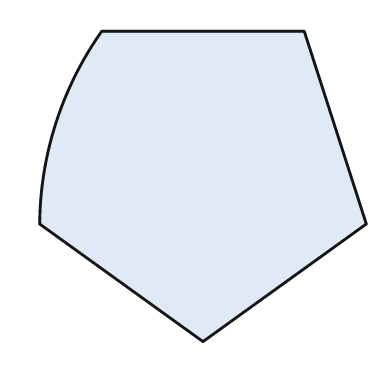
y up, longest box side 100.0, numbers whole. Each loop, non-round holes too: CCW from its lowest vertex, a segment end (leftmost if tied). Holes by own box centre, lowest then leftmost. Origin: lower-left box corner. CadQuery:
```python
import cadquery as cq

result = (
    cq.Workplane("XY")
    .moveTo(50.0, 0.0)
    .lineTo(100.0, 36.0)
    .lineTo(81.0, 95.0)
    .lineTo(19.0, 95.0)
    .threePointArc((5.0, 67.0), (0.0, 36.0))
    .close()
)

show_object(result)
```